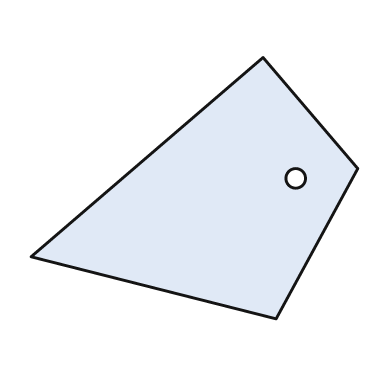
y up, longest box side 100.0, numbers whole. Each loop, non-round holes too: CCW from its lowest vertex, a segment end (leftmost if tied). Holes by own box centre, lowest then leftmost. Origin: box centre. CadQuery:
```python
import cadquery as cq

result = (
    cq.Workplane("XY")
    .moveTo(25.0, -40.0)
    .lineTo(50.0, 6.0)
    .lineTo(21.0, 40.0)
    .lineTo(-50.0, -21.0)
    .close()
    .moveTo(31.0, 3.0)
    .circle(3.0)
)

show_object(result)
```